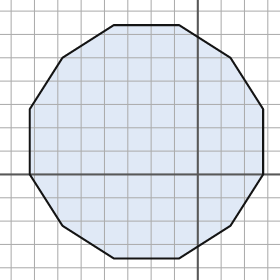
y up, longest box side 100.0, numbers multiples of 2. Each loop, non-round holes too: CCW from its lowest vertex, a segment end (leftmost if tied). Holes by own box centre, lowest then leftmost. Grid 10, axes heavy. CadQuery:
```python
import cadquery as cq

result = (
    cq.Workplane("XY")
    .moveTo(-36.0, -36.0)
    .lineTo(-8.0, -36.0)
    .lineTo(14.0, -22.0)
    .lineTo(28.0, 0.0)
    .lineTo(28.0, 28.0)
    .lineTo(14.0, 50.0)
    .lineTo(-8.0, 64.0)
    .lineTo(-36.0, 64.0)
    .lineTo(-58.0, 50.0)
    .lineTo(-72.0, 28.0)
    .lineTo(-72.0, 0.0)
    .lineTo(-58.0, -22.0)
    .close()
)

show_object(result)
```